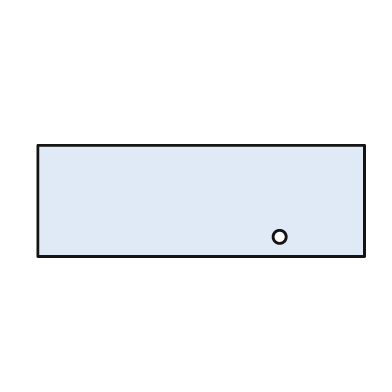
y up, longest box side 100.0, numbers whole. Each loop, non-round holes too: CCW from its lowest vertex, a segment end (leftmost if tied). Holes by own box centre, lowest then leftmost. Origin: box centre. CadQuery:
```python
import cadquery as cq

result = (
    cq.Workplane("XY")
    .moveTo(-50.0, -17.0)
    .lineTo(50.0, -17.0)
    .lineTo(50.0, 17.0)
    .lineTo(-50.0, 17.0)
    .close()
    .moveTo(24.0, -11.0)
    .circle(2.0)
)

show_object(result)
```